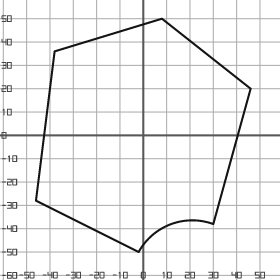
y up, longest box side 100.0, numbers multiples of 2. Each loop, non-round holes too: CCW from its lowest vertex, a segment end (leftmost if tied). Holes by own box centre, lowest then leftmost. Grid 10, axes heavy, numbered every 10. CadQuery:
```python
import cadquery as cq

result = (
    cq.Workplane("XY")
    .moveTo(-2.0, -50.0)
    .threePointArc((12.0, -38.0), (30.0, -38.0))
    .lineTo(46.0, 20.0)
    .lineTo(8.0, 50.0)
    .lineTo(-38.0, 36.0)
    .lineTo(-46.0, -28.0)
    .close()
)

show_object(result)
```